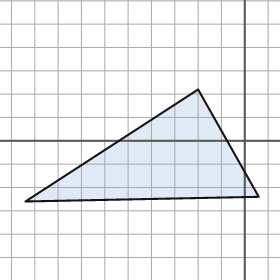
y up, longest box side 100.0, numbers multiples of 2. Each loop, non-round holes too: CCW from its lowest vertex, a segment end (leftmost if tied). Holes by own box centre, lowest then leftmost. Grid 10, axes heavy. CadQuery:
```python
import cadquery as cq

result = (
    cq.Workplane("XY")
    .moveTo(-94.0, -26.0)
    .lineTo(6.0, -24.0)
    .lineTo(-20.0, 22.0)
    .close()
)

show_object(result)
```